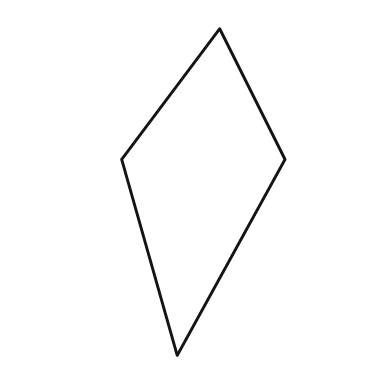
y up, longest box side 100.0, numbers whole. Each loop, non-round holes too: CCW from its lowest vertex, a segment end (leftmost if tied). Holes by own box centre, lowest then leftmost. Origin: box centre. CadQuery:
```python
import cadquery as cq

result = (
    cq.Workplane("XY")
    .moveTo(-8.0, -50.0)
    .lineTo(25.0, 10.0)
    .lineTo(5.0, 50.0)
    .lineTo(-25.0, 10.0)
    .close()
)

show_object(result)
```